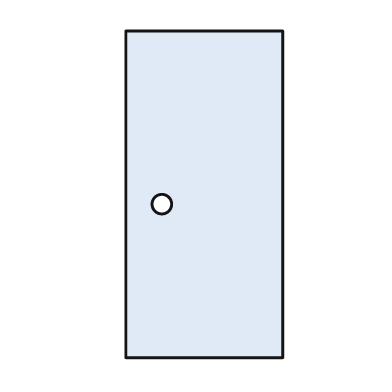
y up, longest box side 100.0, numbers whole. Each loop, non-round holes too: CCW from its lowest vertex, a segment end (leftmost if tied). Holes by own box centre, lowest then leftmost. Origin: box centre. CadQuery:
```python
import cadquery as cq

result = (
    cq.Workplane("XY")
    .moveTo(-24.0, -50.0)
    .lineTo(24.0, -50.0)
    .lineTo(24.0, 50.0)
    .lineTo(-24.0, 50.0)
    .close()
    .moveTo(-13.0, -3.0)
    .circle(3.0)
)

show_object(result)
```